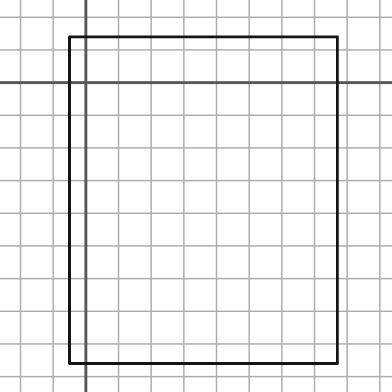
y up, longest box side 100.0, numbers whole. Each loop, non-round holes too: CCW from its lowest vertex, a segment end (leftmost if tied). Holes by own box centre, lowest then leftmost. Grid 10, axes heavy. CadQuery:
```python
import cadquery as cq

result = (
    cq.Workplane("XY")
    .moveTo(-5.0, -86.0)
    .lineTo(77.0, -86.0)
    .lineTo(77.0, 14.0)
    .lineTo(-5.0, 14.0)
    .close()
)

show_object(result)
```